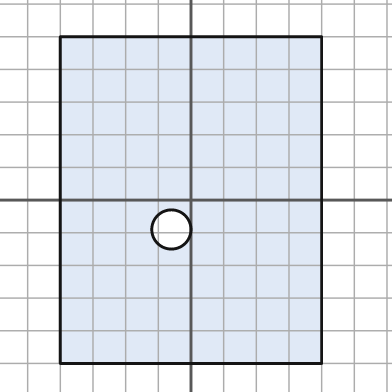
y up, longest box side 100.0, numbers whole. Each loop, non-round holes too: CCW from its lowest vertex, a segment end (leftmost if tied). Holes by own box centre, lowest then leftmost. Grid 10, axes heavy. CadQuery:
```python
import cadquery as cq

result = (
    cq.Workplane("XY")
    .moveTo(-40.0, -50.0)
    .lineTo(40.0, -50.0)
    .lineTo(40.0, 50.0)
    .lineTo(-40.0, 50.0)
    .close()
    .moveTo(-6.0, -9.0)
    .circle(6.0)
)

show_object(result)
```